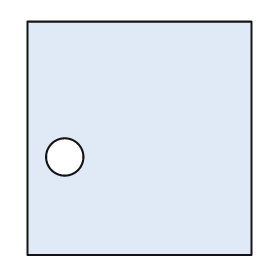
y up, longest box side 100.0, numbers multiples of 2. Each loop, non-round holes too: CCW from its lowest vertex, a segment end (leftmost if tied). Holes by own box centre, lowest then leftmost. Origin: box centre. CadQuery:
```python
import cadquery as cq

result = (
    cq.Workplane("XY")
    .moveTo(-48.0, -50.0)
    .lineTo(48.0, -50.0)
    .lineTo(48.0, 50.0)
    .lineTo(-48.0, 50.0)
    .close()
    .moveTo(-32.0, -8.0)
    .circle(8.0)
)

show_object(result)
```